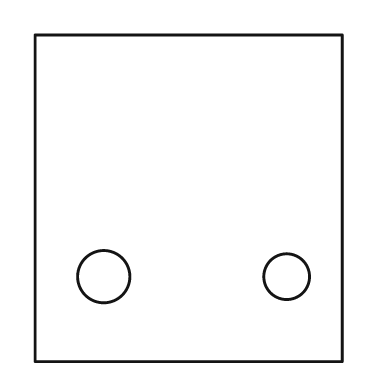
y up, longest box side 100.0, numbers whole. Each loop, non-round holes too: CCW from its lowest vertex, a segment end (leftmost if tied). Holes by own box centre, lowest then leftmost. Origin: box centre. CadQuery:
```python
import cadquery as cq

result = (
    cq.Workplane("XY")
    .moveTo(-47.0, -50.0)
    .lineTo(47.0, -50.0)
    .lineTo(47.0, 50.0)
    .lineTo(-47.0, 50.0)
    .close()
    .moveTo(-26.0, -24.0)
    .circle(8.0)
    .moveTo(30.0, -24.0)
    .circle(7.0)
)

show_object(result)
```